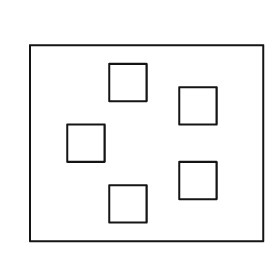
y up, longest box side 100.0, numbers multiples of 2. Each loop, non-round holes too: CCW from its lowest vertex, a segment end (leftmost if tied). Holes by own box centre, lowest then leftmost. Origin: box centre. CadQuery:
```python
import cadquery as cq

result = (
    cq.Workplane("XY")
    .moveTo(-50.0, -42.0)
    .lineTo(50.0, -42.0)
    .lineTo(50.0, 42.0)
    .lineTo(-50.0, 42.0)
    .close()
    .moveTo(-16.0, -34.0)
    .lineTo(0.0, -34.0)
    .lineTo(0.0, -18.0)
    .lineTo(-16.0, -18.0)
    .close()
    .moveTo(14.0, -24.0)
    .lineTo(30.0, -24.0)
    .lineTo(30.0, -8.0)
    .lineTo(14.0, -8.0)
    .close()
    .moveTo(-34.0, -8.0)
    .lineTo(-18.0, -8.0)
    .lineTo(-18.0, 8.0)
    .lineTo(-34.0, 8.0)
    .close()
    .moveTo(14.0, 8.0)
    .lineTo(30.0, 8.0)
    .lineTo(30.0, 24.0)
    .lineTo(14.0, 24.0)
    .close()
    .moveTo(-16.0, 18.0)
    .lineTo(0.0, 18.0)
    .lineTo(0.0, 34.0)
    .lineTo(-16.0, 34.0)
    .close()
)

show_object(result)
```